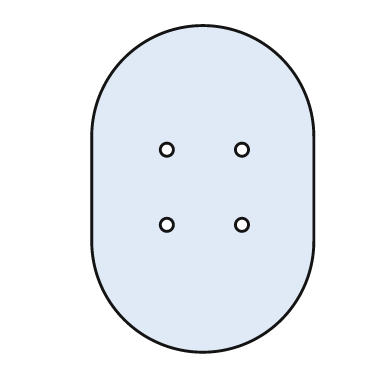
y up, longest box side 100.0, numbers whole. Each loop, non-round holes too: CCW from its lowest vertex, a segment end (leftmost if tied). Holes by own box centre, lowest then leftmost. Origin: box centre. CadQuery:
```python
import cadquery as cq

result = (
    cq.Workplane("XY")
    .moveTo(-34.0, -16.0)
    .threePointArc((0.0, -50.0), (34.0, -16.0))
    .lineTo(34.0, 16.0)
    .threePointArc((0.0, 50.0), (-34.0, 16.0))
    .close()
    .moveTo(-11.0, -11.0)
    .circle(2.0)
    .moveTo(12.0, -11.0)
    .circle(2.0)
    .moveTo(-11.0, 12.0)
    .circle(2.0)
    .moveTo(12.0, 12.0)
    .circle(2.0)
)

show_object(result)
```